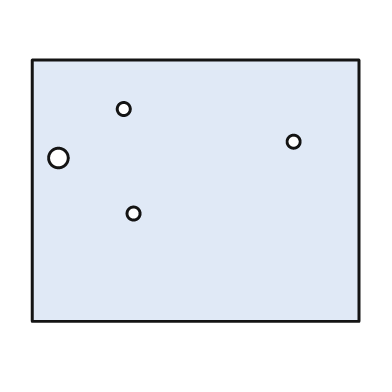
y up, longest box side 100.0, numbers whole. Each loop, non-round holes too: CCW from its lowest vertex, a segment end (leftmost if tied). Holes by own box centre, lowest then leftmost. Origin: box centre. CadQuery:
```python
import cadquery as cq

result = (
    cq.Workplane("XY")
    .moveTo(-50.0, -40.0)
    .lineTo(50.0, -40.0)
    .lineTo(50.0, 40.0)
    .lineTo(-50.0, 40.0)
    .close()
    .moveTo(-19.0, -7.0)
    .circle(2.0)
    .moveTo(-42.0, 10.0)
    .circle(3.0)
    .moveTo(30.0, 15.0)
    .circle(2.0)
    .moveTo(-22.0, 25.0)
    .circle(2.0)
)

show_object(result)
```